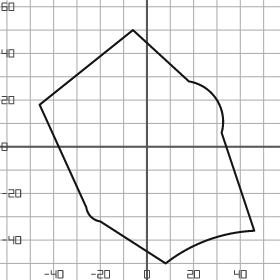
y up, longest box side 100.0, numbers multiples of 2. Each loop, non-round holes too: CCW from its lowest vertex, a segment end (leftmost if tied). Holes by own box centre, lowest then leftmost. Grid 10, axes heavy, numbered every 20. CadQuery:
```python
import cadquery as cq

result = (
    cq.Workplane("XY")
    .moveTo(8.0, -50.0)
    .threePointArc((26.0, -40.0), (46.0, -36.0))
    .lineTo(32.0, 6.0)
    .threePointArc((30.0, 20.0), (18.0, 28.0))
    .lineTo(-6.0, 50.0)
    .lineTo(-46.0, 18.0)
    .lineTo(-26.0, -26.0)
    .threePointArc((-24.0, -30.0), (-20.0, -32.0))
    .close()
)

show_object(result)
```